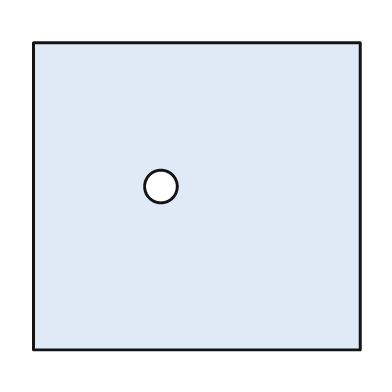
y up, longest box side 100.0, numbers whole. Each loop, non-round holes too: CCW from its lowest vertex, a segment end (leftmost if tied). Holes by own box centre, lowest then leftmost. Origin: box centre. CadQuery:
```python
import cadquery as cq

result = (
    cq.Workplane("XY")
    .moveTo(-50.0, -47.0)
    .lineTo(50.0, -47.0)
    .lineTo(50.0, 47.0)
    .lineTo(-50.0, 47.0)
    .close()
    .moveTo(-11.0, 3.0)
    .circle(5.0)
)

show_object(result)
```